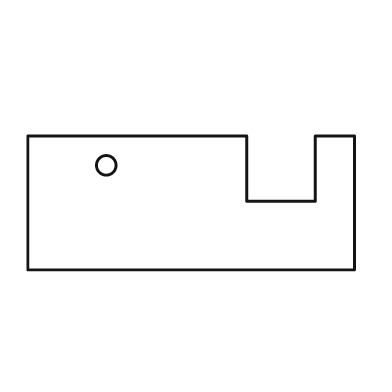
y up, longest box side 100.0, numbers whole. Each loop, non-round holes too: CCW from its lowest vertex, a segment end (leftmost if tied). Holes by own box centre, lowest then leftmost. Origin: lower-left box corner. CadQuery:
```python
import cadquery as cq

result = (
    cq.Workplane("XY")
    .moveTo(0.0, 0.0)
    .lineTo(100.0, 0.0)
    .lineTo(100.0, 41.0)
    .lineTo(88.0, 41.0)
    .lineTo(88.0, 21.0)
    .lineTo(67.0, 21.0)
    .lineTo(67.0, 41.0)
    .lineTo(0.0, 41.0)
    .close()
    .moveTo(24.0, 32.0)
    .circle(3.0)
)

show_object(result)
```